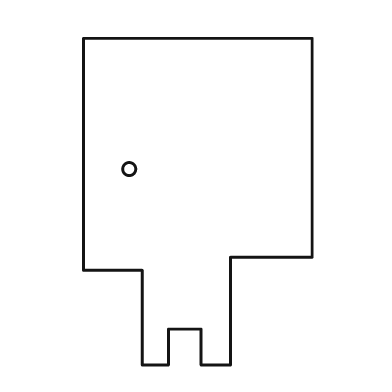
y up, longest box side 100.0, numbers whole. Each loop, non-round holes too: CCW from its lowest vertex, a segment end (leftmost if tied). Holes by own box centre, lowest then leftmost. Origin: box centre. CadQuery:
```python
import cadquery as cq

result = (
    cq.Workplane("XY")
    .moveTo(-17.0, -50.0)
    .lineTo(-9.0, -50.0)
    .lineTo(-9.0, -39.0)
    .lineTo(1.0, -39.0)
    .lineTo(1.0, -50.0)
    .lineTo(10.0, -50.0)
    .lineTo(10.0, -17.0)
    .lineTo(35.0, -17.0)
    .lineTo(35.0, 50.0)
    .lineTo(-35.0, 50.0)
    .lineTo(-35.0, -21.0)
    .lineTo(-17.0, -21.0)
    .close()
    .moveTo(-21.0, 10.0)
    .circle(2.0)
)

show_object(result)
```